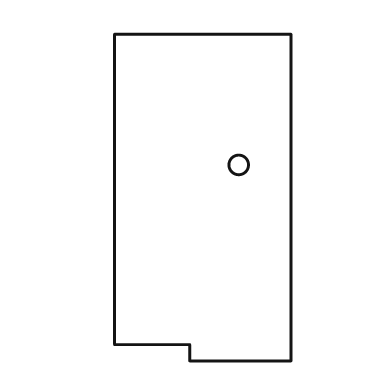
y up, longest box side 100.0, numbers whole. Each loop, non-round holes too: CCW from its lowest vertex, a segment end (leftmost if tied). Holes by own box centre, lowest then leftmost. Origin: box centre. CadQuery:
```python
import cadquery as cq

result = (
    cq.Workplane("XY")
    .moveTo(-4.0, -50.0)
    .lineTo(27.0, -50.0)
    .lineTo(27.0, 50.0)
    .lineTo(-27.0, 50.0)
    .lineTo(-27.0, -45.0)
    .lineTo(-4.0, -45.0)
    .close()
    .moveTo(11.0, 10.0)
    .circle(3.0)
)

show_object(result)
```